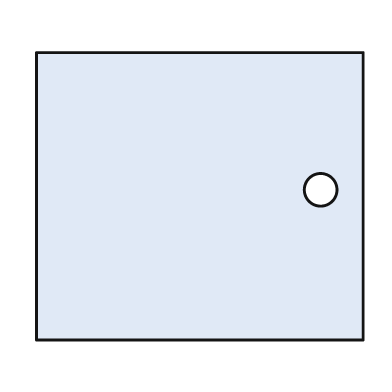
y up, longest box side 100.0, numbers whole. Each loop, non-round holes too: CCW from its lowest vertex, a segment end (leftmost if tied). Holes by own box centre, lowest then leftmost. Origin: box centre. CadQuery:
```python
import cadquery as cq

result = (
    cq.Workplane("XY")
    .moveTo(-50.0, -44.0)
    .lineTo(50.0, -44.0)
    .lineTo(50.0, 44.0)
    .lineTo(-50.0, 44.0)
    .close()
    .moveTo(37.0, 2.0)
    .circle(5.0)
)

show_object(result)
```